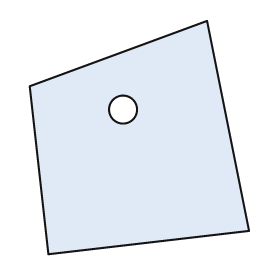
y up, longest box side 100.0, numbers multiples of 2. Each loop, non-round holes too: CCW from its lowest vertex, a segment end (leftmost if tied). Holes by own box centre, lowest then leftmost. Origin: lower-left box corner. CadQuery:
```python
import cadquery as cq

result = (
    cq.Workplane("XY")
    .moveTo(8.0, 0.0)
    .lineTo(94.0, 10.0)
    .lineTo(76.0, 100.0)
    .lineTo(0.0, 72.0)
    .close()
    .moveTo(40.0, 62.0)
    .circle(6.0)
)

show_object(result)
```